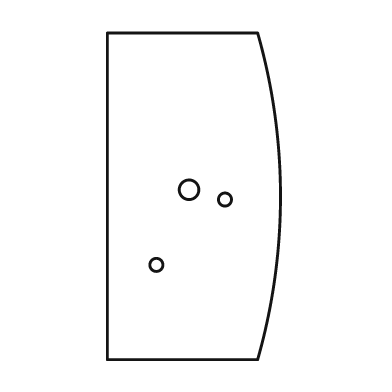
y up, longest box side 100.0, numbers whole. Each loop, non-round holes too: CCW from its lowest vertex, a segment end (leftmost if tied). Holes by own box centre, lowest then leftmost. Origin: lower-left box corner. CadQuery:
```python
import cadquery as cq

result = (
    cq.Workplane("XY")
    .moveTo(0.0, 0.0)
    .lineTo(46.0, 0.0)
    .threePointArc((53.0, 50.0), (46.0, 100.0))
    .lineTo(0.0, 100.0)
    .close()
    .moveTo(15.0, 29.0)
    .circle(2.0)
    .moveTo(36.0, 49.0)
    .circle(2.0)
    .moveTo(25.0, 52.0)
    .circle(3.0)
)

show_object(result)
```